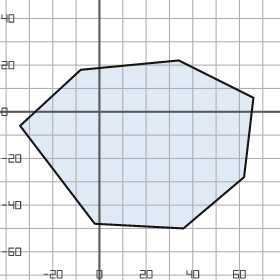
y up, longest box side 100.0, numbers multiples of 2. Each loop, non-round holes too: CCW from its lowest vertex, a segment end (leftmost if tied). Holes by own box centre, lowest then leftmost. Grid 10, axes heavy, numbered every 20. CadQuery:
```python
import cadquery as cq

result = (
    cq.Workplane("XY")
    .moveTo(36.0, -50.0)
    .lineTo(62.0, -28.0)
    .lineTo(66.0, 6.0)
    .lineTo(34.0, 22.0)
    .lineTo(-8.0, 18.0)
    .lineTo(-34.0, -6.0)
    .lineTo(-2.0, -48.0)
    .close()
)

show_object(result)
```